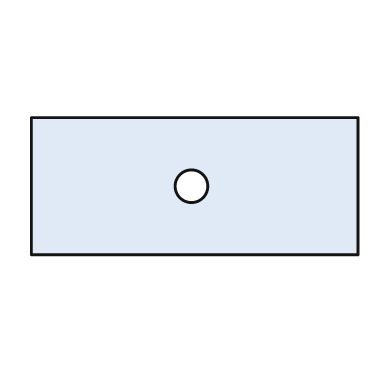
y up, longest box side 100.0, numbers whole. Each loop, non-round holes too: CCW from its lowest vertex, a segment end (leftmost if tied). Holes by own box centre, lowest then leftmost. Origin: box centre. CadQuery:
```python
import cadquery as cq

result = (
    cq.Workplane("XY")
    .moveTo(-50.0, -21.0)
    .lineTo(50.0, -21.0)
    .lineTo(50.0, 21.0)
    .lineTo(-50.0, 21.0)
    .close()
    .moveTo(-1.0, 0.0)
    .circle(5.0)
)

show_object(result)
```